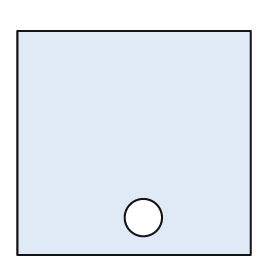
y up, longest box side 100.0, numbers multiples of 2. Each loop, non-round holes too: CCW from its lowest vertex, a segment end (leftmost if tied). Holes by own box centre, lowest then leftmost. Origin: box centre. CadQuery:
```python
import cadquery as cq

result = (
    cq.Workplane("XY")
    .moveTo(-50.0, -48.0)
    .lineTo(50.0, -48.0)
    .lineTo(50.0, 48.0)
    .lineTo(-50.0, 48.0)
    .close()
    .moveTo(4.0, -32.0)
    .circle(8.0)
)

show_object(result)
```